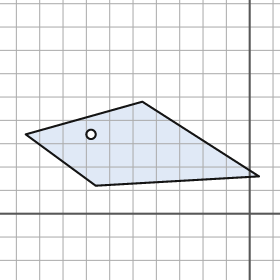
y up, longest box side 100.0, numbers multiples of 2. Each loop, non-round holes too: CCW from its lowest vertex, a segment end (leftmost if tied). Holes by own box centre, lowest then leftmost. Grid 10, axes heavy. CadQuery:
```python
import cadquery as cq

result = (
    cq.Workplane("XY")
    .moveTo(-66.0, 12.0)
    .lineTo(4.0, 16.0)
    .lineTo(-46.0, 48.0)
    .lineTo(-96.0, 34.0)
    .close()
    .moveTo(-68.0, 34.0)
    .circle(2.0)
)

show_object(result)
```